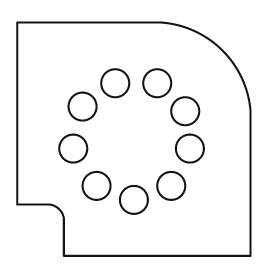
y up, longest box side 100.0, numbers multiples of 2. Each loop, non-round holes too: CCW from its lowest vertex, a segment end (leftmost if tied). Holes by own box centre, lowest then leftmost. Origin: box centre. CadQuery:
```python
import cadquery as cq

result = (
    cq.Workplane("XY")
    .moveTo(-30.0, -50.0)
    .lineTo(50.0, -50.0)
    .lineTo(50.0, 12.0)
    .threePointArc((38.0, 38.0), (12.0, 50.0))
    .lineTo(-50.0, 50.0)
    .lineTo(-50.0, -28.0)
    .lineTo(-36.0, -28.0)
    .threePointArc((-32.0, -30.0), (-30.0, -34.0))
    .close()
    .moveTo(0.0, -26.0)
    .circle(6.0)
    .moveTo(-16.0, -20.0)
    .circle(6.0)
    .moveTo(16.0, -20.0)
    .circle(6.0)
    .moveTo(-26.0, -4.0)
    .circle(6.0)
    .moveTo(24.0, -4.0)
    .circle(6.0)
    .moveTo(22.0, 12.0)
    .circle(6.0)
    .moveTo(-22.0, 14.0)
    .circle(6.0)
    .moveTo(-8.0, 24.0)
    .circle(6.0)
    .moveTo(10.0, 24.0)
    .circle(6.0)
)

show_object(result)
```